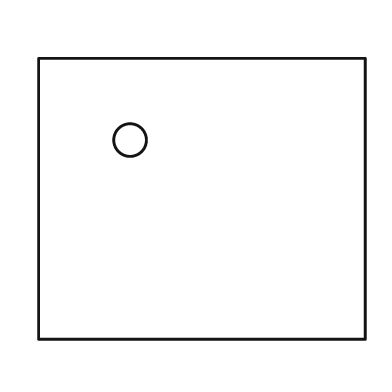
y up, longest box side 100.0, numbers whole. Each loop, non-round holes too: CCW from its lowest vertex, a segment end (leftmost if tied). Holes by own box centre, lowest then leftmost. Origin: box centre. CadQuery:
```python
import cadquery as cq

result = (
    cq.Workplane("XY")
    .moveTo(-50.0, -43.0)
    .lineTo(50.0, -43.0)
    .lineTo(50.0, 43.0)
    .lineTo(-50.0, 43.0)
    .close()
    .moveTo(-22.0, 18.0)
    .circle(5.0)
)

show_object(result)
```